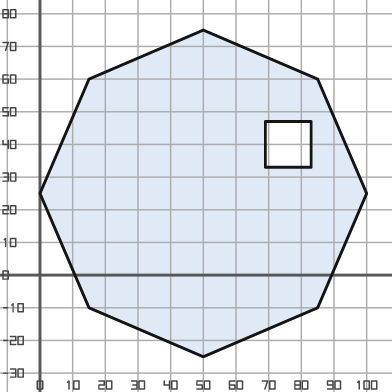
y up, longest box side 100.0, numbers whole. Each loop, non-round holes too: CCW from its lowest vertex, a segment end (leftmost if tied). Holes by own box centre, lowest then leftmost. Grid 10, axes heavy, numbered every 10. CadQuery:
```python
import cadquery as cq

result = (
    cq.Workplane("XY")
    .moveTo(50.0, -25.0)
    .lineTo(85.0, -10.0)
    .lineTo(100.0, 25.0)
    .lineTo(85.0, 60.0)
    .lineTo(50.0, 75.0)
    .lineTo(15.0, 60.0)
    .lineTo(0.0, 25.0)
    .lineTo(15.0, -10.0)
    .close()
    .moveTo(69.0, 33.0)
    .lineTo(83.0, 33.0)
    .lineTo(83.0, 47.0)
    .lineTo(69.0, 47.0)
    .close()
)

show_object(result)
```